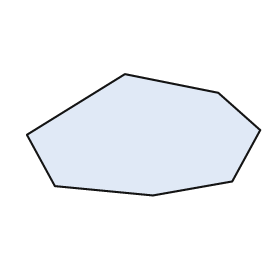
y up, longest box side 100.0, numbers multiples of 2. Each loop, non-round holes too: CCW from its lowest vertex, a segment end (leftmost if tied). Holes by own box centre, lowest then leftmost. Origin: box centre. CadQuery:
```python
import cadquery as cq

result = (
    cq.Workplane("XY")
    .moveTo(4.0, -26.0)
    .lineTo(38.0, -20.0)
    .lineTo(50.0, 2.0)
    .lineTo(32.0, 18.0)
    .lineTo(-8.0, 26.0)
    .lineTo(-50.0, 0.0)
    .lineTo(-38.0, -22.0)
    .close()
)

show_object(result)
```